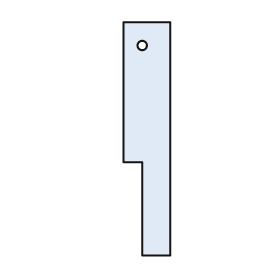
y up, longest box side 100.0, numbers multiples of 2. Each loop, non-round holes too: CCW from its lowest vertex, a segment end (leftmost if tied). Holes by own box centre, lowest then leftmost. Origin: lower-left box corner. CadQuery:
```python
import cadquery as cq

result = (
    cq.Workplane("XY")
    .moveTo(8.0, 0.0)
    .lineTo(20.0, 0.0)
    .lineTo(20.0, 100.0)
    .lineTo(0.0, 100.0)
    .lineTo(0.0, 40.0)
    .lineTo(8.0, 40.0)
    .close()
    .moveTo(8.0, 90.0)
    .circle(2.0)
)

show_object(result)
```